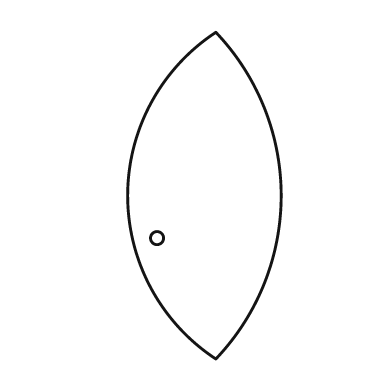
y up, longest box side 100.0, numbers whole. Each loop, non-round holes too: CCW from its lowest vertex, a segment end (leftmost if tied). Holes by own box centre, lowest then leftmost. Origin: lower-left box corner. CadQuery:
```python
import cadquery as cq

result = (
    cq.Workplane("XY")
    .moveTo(27.0, 0.0)
    .threePointArc((47.0, 50.0), (27.0, 100.0))
    .threePointArc((0.0, 50.0), (27.0, 0.0))
    .close()
    .moveTo(9.0, 37.0)
    .circle(2.0)
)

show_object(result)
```